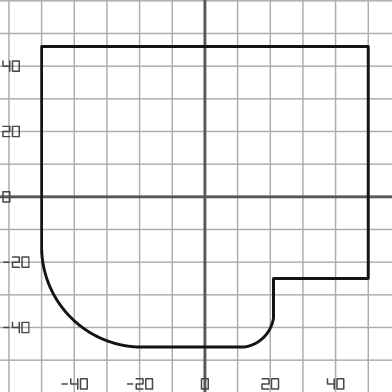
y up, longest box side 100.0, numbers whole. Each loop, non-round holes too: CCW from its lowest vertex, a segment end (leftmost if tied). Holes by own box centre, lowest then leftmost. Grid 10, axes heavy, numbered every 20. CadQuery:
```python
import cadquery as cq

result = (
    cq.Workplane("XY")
    .moveTo(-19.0, -46.0)
    .lineTo(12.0, -46.0)
    .threePointArc((18.0, -43.0), (21.0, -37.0))
    .lineTo(21.0, -25.0)
    .lineTo(50.0, -25.0)
    .lineTo(50.0, 46.0)
    .lineTo(-50.0, 46.0)
    .lineTo(-50.0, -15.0)
    .threePointArc((-41.0, -37.0), (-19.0, -46.0))
    .close()
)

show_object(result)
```